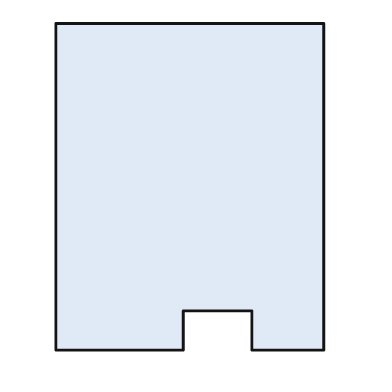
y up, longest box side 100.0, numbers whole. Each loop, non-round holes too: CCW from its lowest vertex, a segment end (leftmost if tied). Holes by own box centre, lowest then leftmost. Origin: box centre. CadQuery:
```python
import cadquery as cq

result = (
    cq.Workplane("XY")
    .moveTo(-41.0, -50.0)
    .lineTo(-2.0, -50.0)
    .lineTo(-2.0, -38.0)
    .lineTo(19.0, -38.0)
    .lineTo(19.0, -50.0)
    .lineTo(41.0, -50.0)
    .lineTo(41.0, 50.0)
    .lineTo(-41.0, 50.0)
    .close()
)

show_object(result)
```